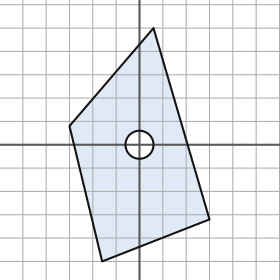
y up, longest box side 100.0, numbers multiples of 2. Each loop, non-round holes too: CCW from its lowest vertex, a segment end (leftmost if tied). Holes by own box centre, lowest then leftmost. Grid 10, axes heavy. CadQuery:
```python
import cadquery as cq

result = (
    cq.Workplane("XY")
    .moveTo(-16.0, -50.0)
    .lineTo(30.0, -32.0)
    .lineTo(6.0, 50.0)
    .lineTo(-30.0, 8.0)
    .close()
    .moveTo(0.0, 0.0)
    .circle(6.0)
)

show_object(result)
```